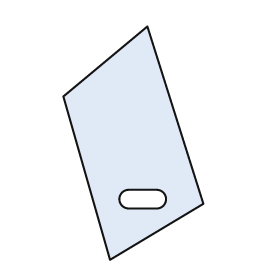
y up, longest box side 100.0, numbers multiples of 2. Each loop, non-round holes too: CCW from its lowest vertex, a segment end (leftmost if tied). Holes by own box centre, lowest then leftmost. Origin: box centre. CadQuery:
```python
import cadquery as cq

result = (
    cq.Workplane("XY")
    .moveTo(-10.0, -50.0)
    .lineTo(30.0, -26.0)
    .lineTo(6.0, 50.0)
    .lineTo(-30.0, 20.0)
    .close()
    .moveTo(-2.0, -28.0)
    .lineTo(10.0, -28.0)
    .threePointArc((14.0, -24.0), (10.0, -20.0))
    .lineTo(-2.0, -20.0)
    .threePointArc((-6.0, -24.0), (-2.0, -28.0))
    .close()
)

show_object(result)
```